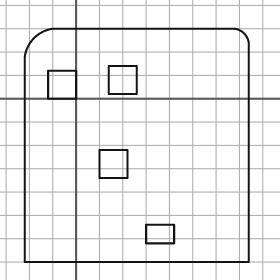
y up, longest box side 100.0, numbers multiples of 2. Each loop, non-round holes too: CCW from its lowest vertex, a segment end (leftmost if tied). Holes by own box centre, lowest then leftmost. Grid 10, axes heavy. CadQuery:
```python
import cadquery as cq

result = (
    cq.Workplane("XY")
    .moveTo(-22.0, -70.0)
    .lineTo(74.0, -70.0)
    .lineTo(74.0, 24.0)
    .threePointArc((72.0, 28.0), (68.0, 30.0))
    .lineTo(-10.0, 30.0)
    .threePointArc((-18.0, 26.0), (-22.0, 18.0))
    .close()
    .moveTo(30.0, -62.0)
    .lineTo(42.0, -62.0)
    .lineTo(42.0, -54.0)
    .lineTo(30.0, -54.0)
    .close()
    .moveTo(10.0, -34.0)
    .lineTo(22.0, -34.0)
    .lineTo(22.0, -22.0)
    .lineTo(10.0, -22.0)
    .close()
    .moveTo(-12.0, 0.0)
    .lineTo(0.0, 0.0)
    .lineTo(0.0, 12.0)
    .lineTo(-12.0, 12.0)
    .close()
    .moveTo(14.0, 2.0)
    .lineTo(26.0, 2.0)
    .lineTo(26.0, 14.0)
    .lineTo(14.0, 14.0)
    .close()
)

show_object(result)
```